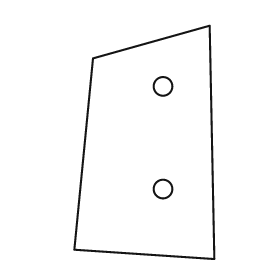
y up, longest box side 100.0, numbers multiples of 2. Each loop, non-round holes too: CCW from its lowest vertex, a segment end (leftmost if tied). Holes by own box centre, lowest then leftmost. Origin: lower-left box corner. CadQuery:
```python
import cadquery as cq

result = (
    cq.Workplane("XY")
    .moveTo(60.0, 0.0)
    .lineTo(58.0, 100.0)
    .lineTo(8.0, 86.0)
    .lineTo(0.0, 4.0)
    .close()
    .moveTo(38.0, 30.0)
    .circle(4.0)
    .moveTo(38.0, 74.0)
    .circle(4.0)
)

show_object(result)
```